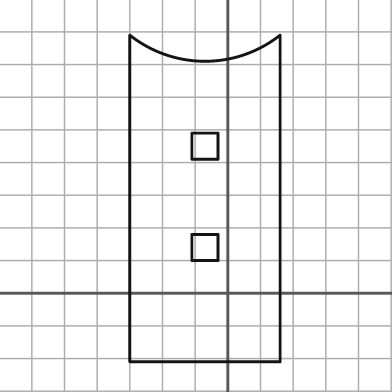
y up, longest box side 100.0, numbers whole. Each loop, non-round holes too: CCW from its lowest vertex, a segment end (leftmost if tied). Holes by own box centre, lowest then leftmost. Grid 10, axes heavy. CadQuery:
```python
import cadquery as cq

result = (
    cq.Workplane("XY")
    .moveTo(-30.0, -21.0)
    .lineTo(16.0, -21.0)
    .lineTo(16.0, 79.0)
    .threePointArc((-7.0, 71.0), (-30.0, 79.0))
    .close()
    .moveTo(-11.0, 10.0)
    .lineTo(-3.0, 10.0)
    .lineTo(-3.0, 18.0)
    .lineTo(-11.0, 18.0)
    .close()
    .moveTo(-11.0, 41.0)
    .lineTo(-3.0, 41.0)
    .lineTo(-3.0, 49.0)
    .lineTo(-11.0, 49.0)
    .close()
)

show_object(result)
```